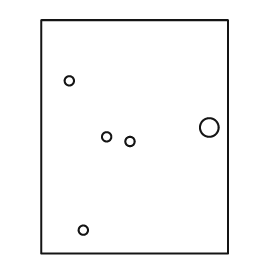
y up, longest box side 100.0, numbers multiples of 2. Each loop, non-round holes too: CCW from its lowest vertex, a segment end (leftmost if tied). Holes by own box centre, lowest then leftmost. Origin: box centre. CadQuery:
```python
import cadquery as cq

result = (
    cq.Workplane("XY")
    .moveTo(-40.0, -50.0)
    .lineTo(40.0, -50.0)
    .lineTo(40.0, 50.0)
    .lineTo(-40.0, 50.0)
    .close()
    .moveTo(-22.0, -40.0)
    .circle(2.0)
    .moveTo(-2.0, -2.0)
    .circle(2.0)
    .moveTo(-12.0, 0.0)
    .circle(2.0)
    .moveTo(32.0, 4.0)
    .circle(4.0)
    .moveTo(-28.0, 24.0)
    .circle(2.0)
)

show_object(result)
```